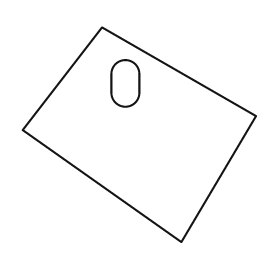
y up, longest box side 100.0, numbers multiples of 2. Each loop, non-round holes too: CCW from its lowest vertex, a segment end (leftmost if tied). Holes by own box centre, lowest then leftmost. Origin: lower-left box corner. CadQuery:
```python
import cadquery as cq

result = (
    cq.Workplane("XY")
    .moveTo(68.0, 0.0)
    .lineTo(100.0, 54.0)
    .lineTo(34.0, 92.0)
    .lineTo(0.0, 48.0)
    .close()
    .moveTo(38.0, 64.0)
    .threePointArc((44.0, 58.0), (50.0, 64.0))
    .lineTo(50.0, 72.0)
    .threePointArc((44.0, 78.0), (38.0, 72.0))
    .close()
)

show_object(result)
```